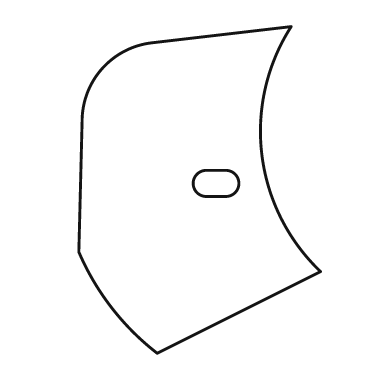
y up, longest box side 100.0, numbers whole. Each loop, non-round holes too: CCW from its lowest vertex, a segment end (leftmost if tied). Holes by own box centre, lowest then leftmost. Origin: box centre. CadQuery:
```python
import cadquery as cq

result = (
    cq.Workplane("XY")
    .moveTo(-13.0, -50.0)
    .lineTo(37.0, -25.0)
    .threePointArc((19.0, 11.0), (28.0, 50.0))
    .lineTo(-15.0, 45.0)
    .threePointArc((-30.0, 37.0), (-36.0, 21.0))
    .lineTo(-37.0, -19.0)
    .threePointArc((-27.0, -36.0), (-13.0, -50.0))
    .close()
    .moveTo(2.0, -2.0)
    .lineTo(8.0, -2.0)
    .threePointArc((12.0, 2.0), (8.0, 6.0))
    .lineTo(2.0, 6.0)
    .threePointArc((-2.0, 2.0), (2.0, -2.0))
    .close()
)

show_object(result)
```